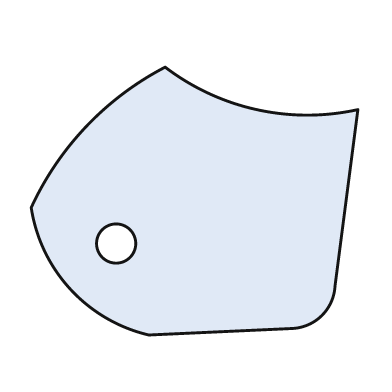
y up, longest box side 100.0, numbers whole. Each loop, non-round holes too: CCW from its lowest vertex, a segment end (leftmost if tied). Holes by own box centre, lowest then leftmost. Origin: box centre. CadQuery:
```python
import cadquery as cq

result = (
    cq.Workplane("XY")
    .moveTo(-14.0, -41.0)
    .lineTo(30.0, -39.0)
    .threePointArc((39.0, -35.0), (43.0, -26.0))
    .lineTo(50.0, 28.0)
    .threePointArc((19.0, 28.0), (-9.0, 41.0))
    .threePointArc((-33.0, 23.0), (-50.0, -2.0))
    .threePointArc((-38.0, -27.0), (-14.0, -41.0))
    .close()
    .moveTo(-24.0, -13.0)
    .circle(6.0)
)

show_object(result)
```